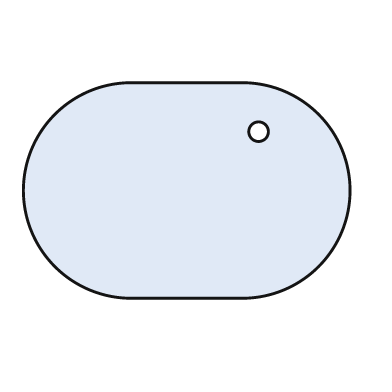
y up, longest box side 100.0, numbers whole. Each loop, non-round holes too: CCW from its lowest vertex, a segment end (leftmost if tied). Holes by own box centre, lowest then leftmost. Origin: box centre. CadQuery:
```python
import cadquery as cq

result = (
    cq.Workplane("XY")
    .moveTo(-17.0, -33.0)
    .lineTo(17.0, -33.0)
    .threePointArc((50.0, 0.0), (17.0, 33.0))
    .lineTo(-17.0, 33.0)
    .threePointArc((-50.0, 0.0), (-17.0, -33.0))
    .close()
    .moveTo(22.0, 18.0)
    .circle(3.0)
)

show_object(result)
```